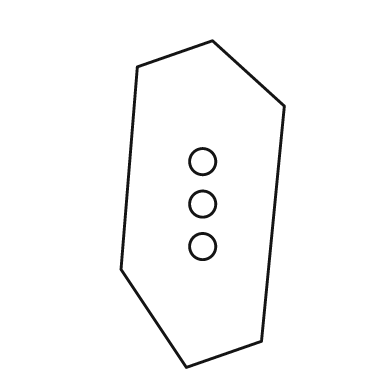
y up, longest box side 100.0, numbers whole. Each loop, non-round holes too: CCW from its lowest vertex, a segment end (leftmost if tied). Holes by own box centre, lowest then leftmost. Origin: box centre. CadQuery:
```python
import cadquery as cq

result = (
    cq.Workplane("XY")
    .moveTo(-5.0, -50.0)
    .lineTo(18.0, -42.0)
    .lineTo(25.0, 30.0)
    .lineTo(3.0, 50.0)
    .lineTo(-20.0, 42.0)
    .lineTo(-25.0, -20.0)
    .close()
    .moveTo(0.0, -13.0)
    .circle(4.0)
    .moveTo(0.0, 0.0)
    .circle(4.0)
    .moveTo(0.0, 13.0)
    .circle(4.0)
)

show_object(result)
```